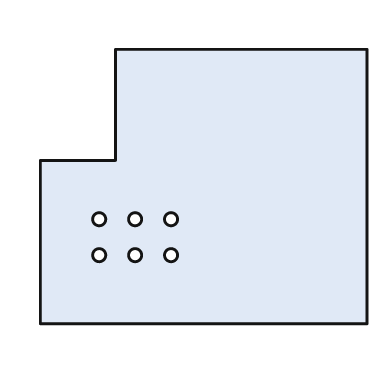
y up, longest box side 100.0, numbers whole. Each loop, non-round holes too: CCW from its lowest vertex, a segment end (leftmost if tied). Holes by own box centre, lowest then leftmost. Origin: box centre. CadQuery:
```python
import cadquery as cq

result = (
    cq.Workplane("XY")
    .moveTo(-50.0, -42.0)
    .lineTo(50.0, -42.0)
    .lineTo(50.0, 42.0)
    .lineTo(-27.0, 42.0)
    .lineTo(-27.0, 8.0)
    .lineTo(-50.0, 8.0)
    .close()
    .moveTo(-32.0, -21.0)
    .circle(2.0)
    .moveTo(-21.0, -21.0)
    .circle(2.0)
    .moveTo(-10.0, -21.0)
    .circle(2.0)
    .moveTo(-32.0, -10.0)
    .circle(2.0)
    .moveTo(-21.0, -10.0)
    .circle(2.0)
    .moveTo(-10.0, -10.0)
    .circle(2.0)
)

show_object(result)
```